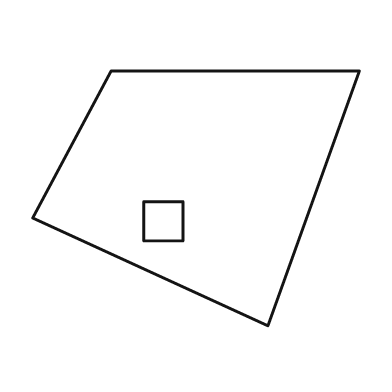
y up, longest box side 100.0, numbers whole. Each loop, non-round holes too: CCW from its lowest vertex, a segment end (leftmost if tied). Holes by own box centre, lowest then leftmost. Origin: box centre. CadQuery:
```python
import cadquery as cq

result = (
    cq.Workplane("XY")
    .moveTo(22.0, -39.0)
    .lineTo(50.0, 39.0)
    .lineTo(-26.0, 39.0)
    .lineTo(-50.0, -6.0)
    .close()
    .moveTo(-16.0, -13.0)
    .lineTo(-4.0, -13.0)
    .lineTo(-4.0, -1.0)
    .lineTo(-16.0, -1.0)
    .close()
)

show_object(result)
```